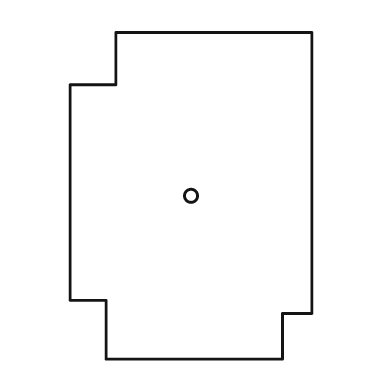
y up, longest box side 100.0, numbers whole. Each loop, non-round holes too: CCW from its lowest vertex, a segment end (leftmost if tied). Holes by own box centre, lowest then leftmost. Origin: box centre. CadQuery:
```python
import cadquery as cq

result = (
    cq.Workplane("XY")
    .moveTo(-26.0, -50.0)
    .lineTo(28.0, -50.0)
    .lineTo(28.0, -36.0)
    .lineTo(37.0, -36.0)
    .lineTo(37.0, 50.0)
    .lineTo(-23.0, 50.0)
    .lineTo(-23.0, 34.0)
    .lineTo(-37.0, 34.0)
    .lineTo(-37.0, -32.0)
    .lineTo(-26.0, -32.0)
    .close()
    .moveTo(0.0, 0.0)
    .circle(2.0)
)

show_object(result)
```